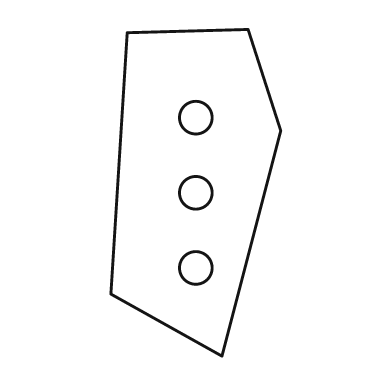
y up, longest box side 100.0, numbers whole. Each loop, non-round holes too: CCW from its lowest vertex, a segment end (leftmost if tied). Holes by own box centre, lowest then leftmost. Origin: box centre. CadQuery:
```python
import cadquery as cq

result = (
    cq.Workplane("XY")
    .moveTo(8.0, -50.0)
    .lineTo(26.0, 19.0)
    .lineTo(16.0, 50.0)
    .lineTo(-21.0, 49.0)
    .lineTo(-26.0, -31.0)
    .close()
    .moveTo(0.0, -23.0)
    .circle(5.0)
    .moveTo(0.0, 0.0)
    .circle(5.0)
    .moveTo(0.0, 23.0)
    .circle(5.0)
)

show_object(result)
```